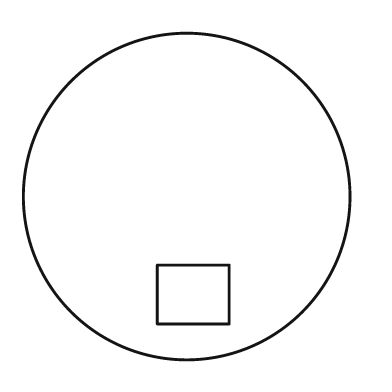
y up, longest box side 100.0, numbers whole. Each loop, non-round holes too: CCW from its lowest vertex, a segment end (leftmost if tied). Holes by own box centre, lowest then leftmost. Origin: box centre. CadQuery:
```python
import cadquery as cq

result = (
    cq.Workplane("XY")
    .moveTo(0.0, 0.0)
    .circle(50.0)
    .moveTo(-9.0, -39.0)
    .lineTo(13.0, -39.0)
    .lineTo(13.0, -21.0)
    .lineTo(-9.0, -21.0)
    .close()
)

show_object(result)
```